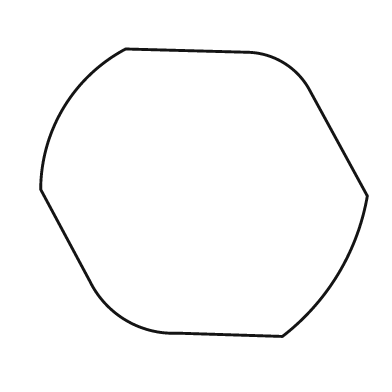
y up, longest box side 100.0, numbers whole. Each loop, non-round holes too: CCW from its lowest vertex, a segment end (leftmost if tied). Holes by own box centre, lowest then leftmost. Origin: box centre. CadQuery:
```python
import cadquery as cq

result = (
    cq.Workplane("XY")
    .moveTo(24.0, -44.0)
    .threePointArc((41.0, -25.0), (50.0, -1.0))
    .lineTo(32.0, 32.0)
    .threePointArc((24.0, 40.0), (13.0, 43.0))
    .lineTo(-24.0, 44.0)
    .threePointArc((-43.0, 26.0), (-50.0, 1.0))
    .lineTo(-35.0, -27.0)
    .threePointArc((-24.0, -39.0), (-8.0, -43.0))
    .close()
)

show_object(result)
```